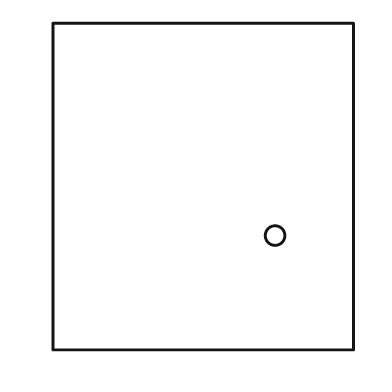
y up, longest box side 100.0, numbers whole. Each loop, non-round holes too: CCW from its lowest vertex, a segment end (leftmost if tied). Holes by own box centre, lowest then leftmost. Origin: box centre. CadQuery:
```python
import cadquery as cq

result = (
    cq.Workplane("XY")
    .moveTo(-46.0, -50.0)
    .lineTo(46.0, -50.0)
    .lineTo(46.0, 50.0)
    .lineTo(-46.0, 50.0)
    .close()
    .moveTo(22.0, -15.0)
    .circle(3.0)
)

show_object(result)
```